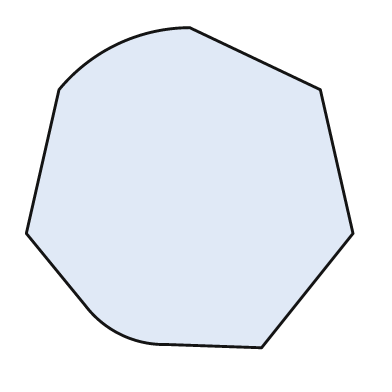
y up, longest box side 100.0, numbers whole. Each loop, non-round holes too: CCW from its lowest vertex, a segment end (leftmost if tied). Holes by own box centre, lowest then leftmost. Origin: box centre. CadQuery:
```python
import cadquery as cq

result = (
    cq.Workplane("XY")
    .moveTo(22.0, -49.0)
    .lineTo(50.0, -14.0)
    .lineTo(40.0, 30.0)
    .lineTo(0.0, 49.0)
    .threePointArc((-22.0, 44.0), (-40.0, 30.0))
    .lineTo(-50.0, -14.0)
    .lineTo(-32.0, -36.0)
    .threePointArc((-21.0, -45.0), (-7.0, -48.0))
    .close()
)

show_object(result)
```